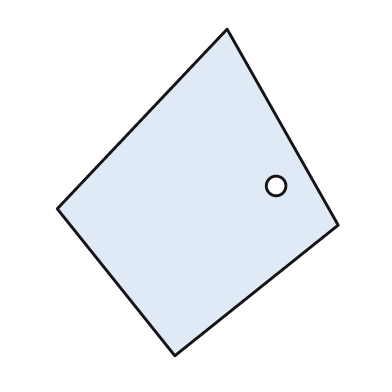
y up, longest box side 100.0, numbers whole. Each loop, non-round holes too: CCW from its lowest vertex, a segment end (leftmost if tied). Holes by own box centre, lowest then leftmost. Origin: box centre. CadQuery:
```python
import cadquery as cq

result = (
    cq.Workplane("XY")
    .moveTo(-7.0, -50.0)
    .lineTo(43.0, -10.0)
    .lineTo(9.0, 50.0)
    .lineTo(-43.0, -5.0)
    .close()
    .moveTo(24.0, 2.0)
    .circle(3.0)
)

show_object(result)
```